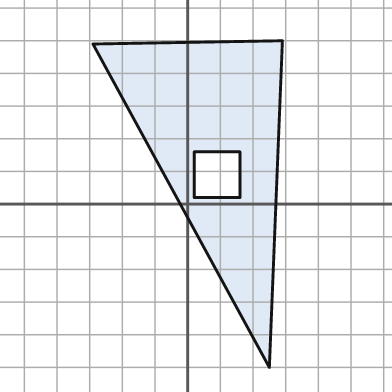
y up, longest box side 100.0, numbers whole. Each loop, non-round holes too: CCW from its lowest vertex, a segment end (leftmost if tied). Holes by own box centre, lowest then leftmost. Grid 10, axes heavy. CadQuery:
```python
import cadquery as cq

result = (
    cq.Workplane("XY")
    .moveTo(25.0, -50.0)
    .lineTo(29.0, 50.0)
    .lineTo(-29.0, 49.0)
    .close()
    .moveTo(2.0, 2.0)
    .lineTo(16.0, 2.0)
    .lineTo(16.0, 16.0)
    .lineTo(2.0, 16.0)
    .close()
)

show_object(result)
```